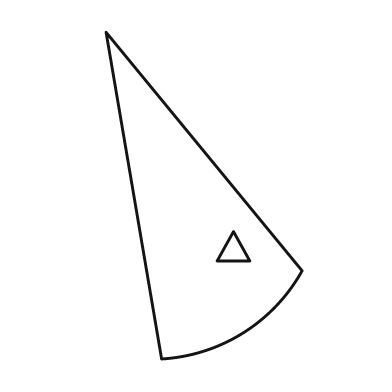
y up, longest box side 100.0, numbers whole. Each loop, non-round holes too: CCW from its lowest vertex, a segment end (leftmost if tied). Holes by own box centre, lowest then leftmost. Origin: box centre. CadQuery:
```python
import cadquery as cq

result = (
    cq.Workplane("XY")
    .moveTo(-13.0, -50.0)
    .threePointArc((12.0, -42.0), (30.0, -23.0))
    .lineTo(-30.0, 50.0)
    .close()
    .moveTo(4.0, -20.0)
    .lineTo(14.0, -20.0)
    .lineTo(9.0, -11.0)
    .close()
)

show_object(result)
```